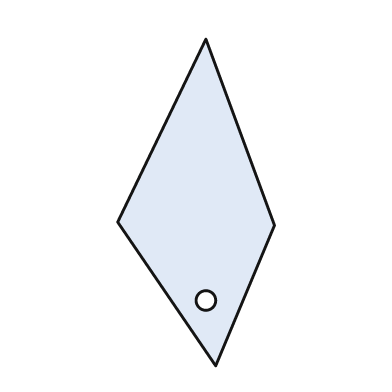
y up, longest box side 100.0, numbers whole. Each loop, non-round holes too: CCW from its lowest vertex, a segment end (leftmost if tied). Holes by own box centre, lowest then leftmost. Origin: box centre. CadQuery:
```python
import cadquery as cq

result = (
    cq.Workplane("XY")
    .moveTo(6.0, -50.0)
    .lineTo(24.0, -7.0)
    .lineTo(3.0, 50.0)
    .lineTo(-24.0, -6.0)
    .close()
    .moveTo(3.0, -30.0)
    .circle(3.0)
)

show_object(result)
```